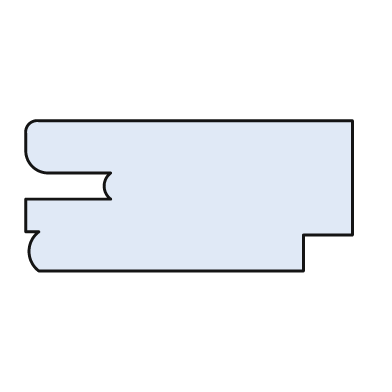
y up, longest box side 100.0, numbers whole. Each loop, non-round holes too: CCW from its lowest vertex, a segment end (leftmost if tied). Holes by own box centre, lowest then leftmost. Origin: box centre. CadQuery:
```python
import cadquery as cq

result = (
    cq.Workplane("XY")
    .moveTo(-46.0, -23.0)
    .lineTo(35.0, -23.0)
    .lineTo(35.0, -12.0)
    .lineTo(50.0, -12.0)
    .lineTo(50.0, 23.0)
    .lineTo(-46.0, 23.0)
    .threePointArc((-49.0, 22.0), (-50.0, 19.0))
    .lineTo(-50.0, 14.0)
    .threePointArc((-48.0, 9.0), (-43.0, 7.0))
    .lineTo(-24.0, 7.0)
    .threePointArc((-26.0, 3.0), (-24.0, -1.0))
    .lineTo(-50.0, -1.0)
    .lineTo(-50.0, -11.0)
    .lineTo(-46.0, -11.0)
    .threePointArc((-49.0, -17.0), (-46.0, -23.0))
    .close()
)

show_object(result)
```